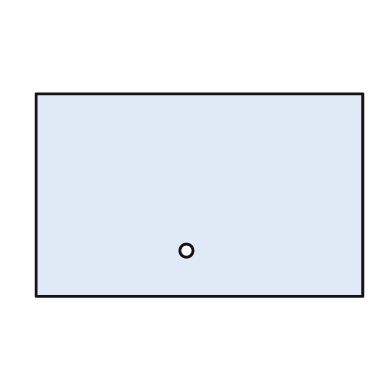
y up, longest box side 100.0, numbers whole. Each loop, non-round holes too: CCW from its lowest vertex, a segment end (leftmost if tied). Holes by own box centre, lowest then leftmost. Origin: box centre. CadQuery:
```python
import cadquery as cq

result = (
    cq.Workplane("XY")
    .moveTo(-50.0, -31.0)
    .lineTo(50.0, -31.0)
    .lineTo(50.0, 31.0)
    .lineTo(-50.0, 31.0)
    .close()
    .moveTo(-4.0, -17.0)
    .circle(2.0)
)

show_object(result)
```